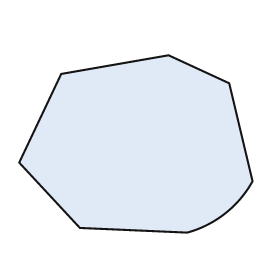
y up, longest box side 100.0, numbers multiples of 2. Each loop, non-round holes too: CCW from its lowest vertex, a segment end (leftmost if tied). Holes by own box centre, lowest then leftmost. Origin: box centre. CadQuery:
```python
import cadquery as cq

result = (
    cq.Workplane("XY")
    .moveTo(22.0, -38.0)
    .threePointArc((38.0, -30.0), (50.0, -16.0))
    .lineTo(40.0, 26.0)
    .lineTo(14.0, 38.0)
    .lineTo(-32.0, 30.0)
    .lineTo(-50.0, -8.0)
    .lineTo(-24.0, -36.0)
    .close()
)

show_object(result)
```